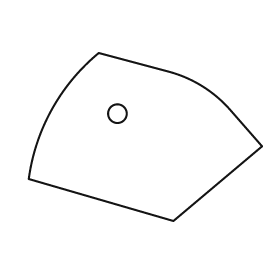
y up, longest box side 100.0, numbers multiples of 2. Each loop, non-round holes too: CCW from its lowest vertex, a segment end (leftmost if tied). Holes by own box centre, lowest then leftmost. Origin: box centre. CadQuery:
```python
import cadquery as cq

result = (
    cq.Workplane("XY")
    .moveTo(12.0, -36.0)
    .lineTo(50.0, -4.0)
    .lineTo(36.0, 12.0)
    .threePointArc((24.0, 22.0), (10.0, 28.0))
    .lineTo(-20.0, 36.0)
    .threePointArc((-40.0, 12.0), (-50.0, -18.0))
    .close()
    .moveTo(-12.0, 10.0)
    .circle(4.0)
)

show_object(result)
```